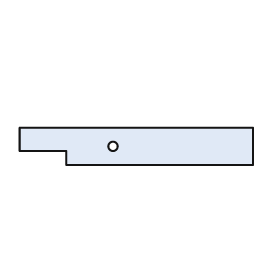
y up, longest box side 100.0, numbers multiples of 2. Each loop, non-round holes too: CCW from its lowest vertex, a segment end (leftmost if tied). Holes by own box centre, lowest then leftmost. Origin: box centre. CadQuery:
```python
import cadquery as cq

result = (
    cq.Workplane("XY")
    .moveTo(-30.0, -8.0)
    .lineTo(50.0, -8.0)
    .lineTo(50.0, 8.0)
    .lineTo(-50.0, 8.0)
    .lineTo(-50.0, -2.0)
    .lineTo(-30.0, -2.0)
    .close()
    .moveTo(-10.0, 0.0)
    .circle(2.0)
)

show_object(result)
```